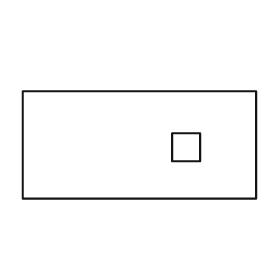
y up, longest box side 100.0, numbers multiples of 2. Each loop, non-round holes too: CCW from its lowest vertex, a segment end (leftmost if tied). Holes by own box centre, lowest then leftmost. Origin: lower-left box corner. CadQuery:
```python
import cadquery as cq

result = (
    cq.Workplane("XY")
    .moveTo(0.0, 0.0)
    .lineTo(100.0, 0.0)
    .lineTo(100.0, 46.0)
    .lineTo(0.0, 46.0)
    .close()
    .moveTo(64.0, 16.0)
    .lineTo(76.0, 16.0)
    .lineTo(76.0, 28.0)
    .lineTo(64.0, 28.0)
    .close()
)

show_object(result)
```